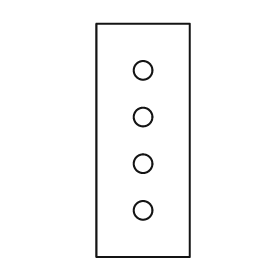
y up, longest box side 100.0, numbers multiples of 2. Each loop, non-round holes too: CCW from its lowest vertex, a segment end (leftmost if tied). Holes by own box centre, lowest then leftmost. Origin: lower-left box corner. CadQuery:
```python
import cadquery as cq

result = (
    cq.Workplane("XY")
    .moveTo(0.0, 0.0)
    .lineTo(40.0, 0.0)
    .lineTo(40.0, 100.0)
    .lineTo(0.0, 100.0)
    .close()
    .moveTo(20.0, 20.0)
    .circle(4.0)
    .moveTo(20.0, 40.0)
    .circle(4.0)
    .moveTo(20.0, 60.0)
    .circle(4.0)
    .moveTo(20.0, 80.0)
    .circle(4.0)
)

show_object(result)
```